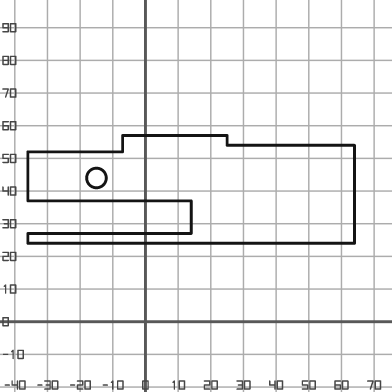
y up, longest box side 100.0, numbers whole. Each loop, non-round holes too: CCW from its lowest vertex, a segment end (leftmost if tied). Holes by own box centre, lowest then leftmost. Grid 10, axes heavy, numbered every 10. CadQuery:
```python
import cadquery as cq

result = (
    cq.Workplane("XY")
    .moveTo(-36.0, 24.0)
    .lineTo(64.0, 24.0)
    .lineTo(64.0, 54.0)
    .lineTo(25.0, 54.0)
    .lineTo(25.0, 57.0)
    .lineTo(-7.0, 57.0)
    .lineTo(-7.0, 52.0)
    .lineTo(-36.0, 52.0)
    .lineTo(-36.0, 37.0)
    .lineTo(14.0, 37.0)
    .lineTo(14.0, 27.0)
    .lineTo(-36.0, 27.0)
    .close()
    .moveTo(-15.0, 44.0)
    .circle(3.0)
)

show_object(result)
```